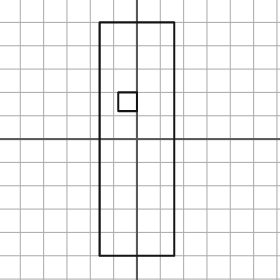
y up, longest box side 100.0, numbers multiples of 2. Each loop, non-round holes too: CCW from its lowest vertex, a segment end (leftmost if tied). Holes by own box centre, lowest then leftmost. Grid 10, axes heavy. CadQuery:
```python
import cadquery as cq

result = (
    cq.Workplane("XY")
    .moveTo(-16.0, -50.0)
    .lineTo(16.0, -50.0)
    .lineTo(16.0, 50.0)
    .lineTo(-16.0, 50.0)
    .close()
    .moveTo(-8.0, 12.0)
    .lineTo(0.0, 12.0)
    .lineTo(0.0, 20.0)
    .lineTo(-8.0, 20.0)
    .close()
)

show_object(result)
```